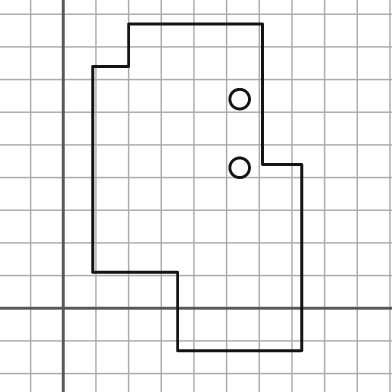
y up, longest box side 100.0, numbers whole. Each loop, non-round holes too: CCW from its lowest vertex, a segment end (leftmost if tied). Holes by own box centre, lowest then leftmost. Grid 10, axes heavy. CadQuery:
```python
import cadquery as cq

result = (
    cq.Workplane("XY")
    .moveTo(35.0, -13.0)
    .lineTo(73.0, -13.0)
    .lineTo(73.0, 44.0)
    .lineTo(61.0, 44.0)
    .lineTo(61.0, 87.0)
    .lineTo(20.0, 87.0)
    .lineTo(20.0, 74.0)
    .lineTo(9.0, 74.0)
    .lineTo(9.0, 11.0)
    .lineTo(35.0, 11.0)
    .close()
    .moveTo(54.0, 43.0)
    .circle(3.0)
    .moveTo(54.0, 64.0)
    .circle(3.0)
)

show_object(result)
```